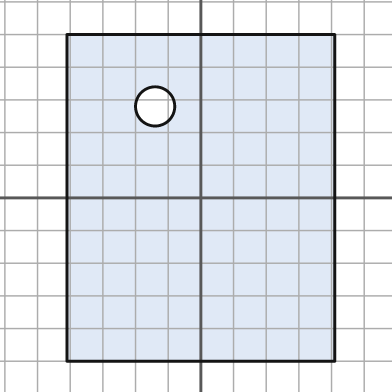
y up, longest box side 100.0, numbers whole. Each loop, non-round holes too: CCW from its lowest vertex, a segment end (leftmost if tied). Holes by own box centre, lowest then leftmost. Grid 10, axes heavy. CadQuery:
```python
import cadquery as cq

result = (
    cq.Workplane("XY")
    .moveTo(-41.0, -50.0)
    .lineTo(41.0, -50.0)
    .lineTo(41.0, 50.0)
    .lineTo(-41.0, 50.0)
    .close()
    .moveTo(-14.0, 28.0)
    .circle(6.0)
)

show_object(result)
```